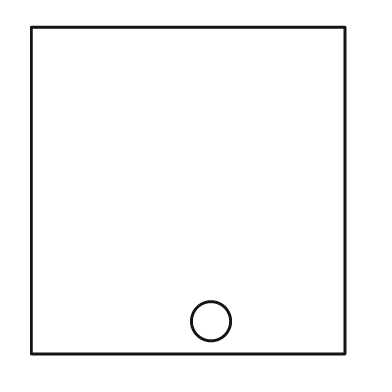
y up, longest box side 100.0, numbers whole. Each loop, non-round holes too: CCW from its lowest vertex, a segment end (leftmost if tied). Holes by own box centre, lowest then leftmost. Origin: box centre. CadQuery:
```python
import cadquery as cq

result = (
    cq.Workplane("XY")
    .moveTo(-48.0, -50.0)
    .lineTo(48.0, -50.0)
    .lineTo(48.0, 50.0)
    .lineTo(-48.0, 50.0)
    .close()
    .moveTo(7.0, -40.0)
    .circle(6.0)
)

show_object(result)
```